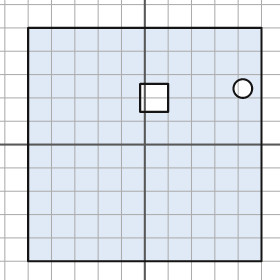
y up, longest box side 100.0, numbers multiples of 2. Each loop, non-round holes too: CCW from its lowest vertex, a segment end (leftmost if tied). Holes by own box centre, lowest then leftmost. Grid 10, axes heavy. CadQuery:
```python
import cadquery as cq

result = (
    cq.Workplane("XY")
    .moveTo(-50.0, -50.0)
    .lineTo(50.0, -50.0)
    .lineTo(50.0, 50.0)
    .lineTo(-50.0, 50.0)
    .close()
    .moveTo(-2.0, 14.0)
    .lineTo(10.0, 14.0)
    .lineTo(10.0, 26.0)
    .lineTo(-2.0, 26.0)
    .close()
    .moveTo(42.0, 24.0)
    .circle(4.0)
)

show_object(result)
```